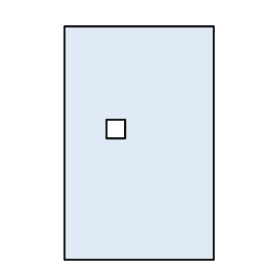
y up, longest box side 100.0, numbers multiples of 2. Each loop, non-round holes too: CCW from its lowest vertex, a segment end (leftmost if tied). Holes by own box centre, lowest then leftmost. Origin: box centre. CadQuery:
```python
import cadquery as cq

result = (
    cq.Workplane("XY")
    .moveTo(-32.0, -50.0)
    .lineTo(32.0, -50.0)
    .lineTo(32.0, 50.0)
    .lineTo(-32.0, 50.0)
    .close()
    .moveTo(-14.0, 2.0)
    .lineTo(-6.0, 2.0)
    .lineTo(-6.0, 10.0)
    .lineTo(-14.0, 10.0)
    .close()
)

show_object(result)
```